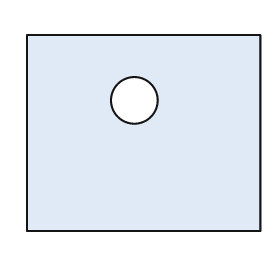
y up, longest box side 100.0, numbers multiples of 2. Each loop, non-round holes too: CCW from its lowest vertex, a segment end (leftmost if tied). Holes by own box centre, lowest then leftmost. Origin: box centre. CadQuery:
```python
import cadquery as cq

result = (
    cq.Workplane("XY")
    .moveTo(-50.0, -42.0)
    .lineTo(50.0, -42.0)
    .lineTo(50.0, 42.0)
    .lineTo(-50.0, 42.0)
    .close()
    .moveTo(-4.0, 14.0)
    .circle(10.0)
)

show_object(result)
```